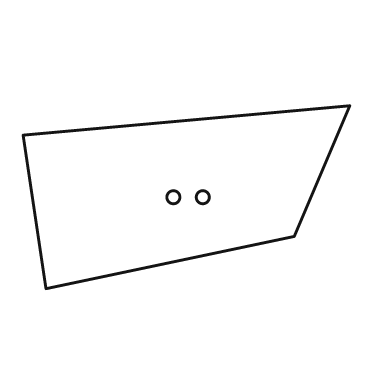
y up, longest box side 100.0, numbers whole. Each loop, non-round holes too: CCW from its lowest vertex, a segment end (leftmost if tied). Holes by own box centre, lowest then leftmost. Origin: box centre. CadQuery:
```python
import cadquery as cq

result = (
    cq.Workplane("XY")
    .moveTo(-43.0, -28.0)
    .lineTo(33.0, -12.0)
    .lineTo(50.0, 28.0)
    .lineTo(-50.0, 19.0)
    .close()
    .moveTo(-4.0, 0.0)
    .circle(2.0)
    .moveTo(5.0, 0.0)
    .circle(2.0)
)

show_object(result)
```